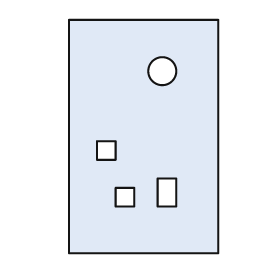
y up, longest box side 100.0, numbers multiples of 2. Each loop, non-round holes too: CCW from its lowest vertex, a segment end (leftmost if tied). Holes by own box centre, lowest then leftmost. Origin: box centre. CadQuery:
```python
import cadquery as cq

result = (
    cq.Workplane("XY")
    .moveTo(-32.0, -50.0)
    .lineTo(32.0, -50.0)
    .lineTo(32.0, 50.0)
    .lineTo(-32.0, 50.0)
    .close()
    .moveTo(-12.0, -30.0)
    .lineTo(-4.0, -30.0)
    .lineTo(-4.0, -22.0)
    .lineTo(-12.0, -22.0)
    .close()
    .moveTo(6.0, -30.0)
    .lineTo(14.0, -30.0)
    .lineTo(14.0, -18.0)
    .lineTo(6.0, -18.0)
    .close()
    .moveTo(-20.0, -10.0)
    .lineTo(-12.0, -10.0)
    .lineTo(-12.0, -2.0)
    .lineTo(-20.0, -2.0)
    .close()
    .moveTo(8.0, 28.0)
    .circle(6.0)
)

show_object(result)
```